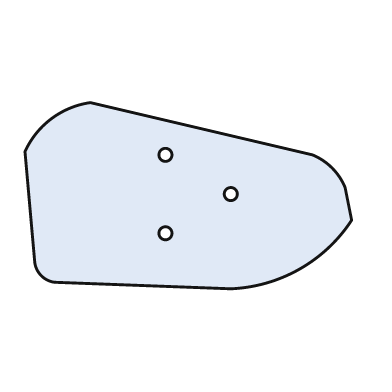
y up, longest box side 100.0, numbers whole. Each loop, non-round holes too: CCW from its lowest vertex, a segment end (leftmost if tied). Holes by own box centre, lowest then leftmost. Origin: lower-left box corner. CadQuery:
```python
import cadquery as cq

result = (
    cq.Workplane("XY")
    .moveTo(63.0, 0.0)
    .threePointArc((84.0, 6.0), (100.0, 21.0))
    .lineTo(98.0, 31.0)
    .threePointArc((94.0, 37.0), (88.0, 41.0))
    .lineTo(20.0, 57.0)
    .threePointArc((8.0, 52.0), (0.0, 42.0))
    .lineTo(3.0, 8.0)
    .threePointArc((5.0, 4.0), (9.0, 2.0))
    .close()
    .moveTo(43.0, 17.0)
    .circle(2.0)
    .moveTo(63.0, 29.0)
    .circle(2.0)
    .moveTo(43.0, 41.0)
    .circle(2.0)
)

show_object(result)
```